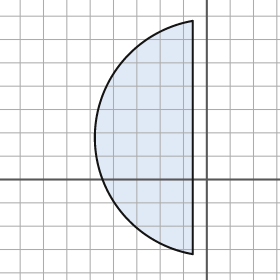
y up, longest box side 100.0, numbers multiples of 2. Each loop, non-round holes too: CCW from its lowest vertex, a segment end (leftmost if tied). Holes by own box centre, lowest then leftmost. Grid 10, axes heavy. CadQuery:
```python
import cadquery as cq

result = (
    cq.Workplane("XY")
    .moveTo(-6.0, -32.0)
    .lineTo(-6.0, 68.0)
    .threePointArc((-48.0, 18.0), (-6.0, -32.0))
    .close()
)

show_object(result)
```